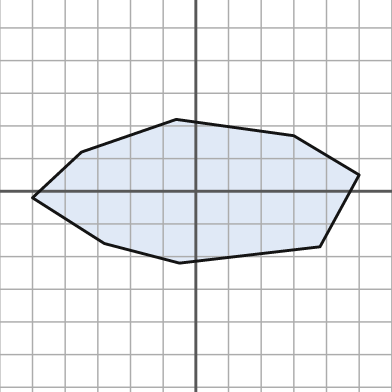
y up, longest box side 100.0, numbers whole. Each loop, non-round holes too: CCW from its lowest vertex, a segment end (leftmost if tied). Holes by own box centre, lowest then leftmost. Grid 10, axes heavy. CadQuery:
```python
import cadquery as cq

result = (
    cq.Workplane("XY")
    .moveTo(-5.0, -22.0)
    .lineTo(38.0, -17.0)
    .lineTo(50.0, 5.0)
    .lineTo(30.0, 17.0)
    .lineTo(-6.0, 22.0)
    .lineTo(-35.0, 12.0)
    .lineTo(-50.0, -2.0)
    .lineTo(-28.0, -16.0)
    .close()
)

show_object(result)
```